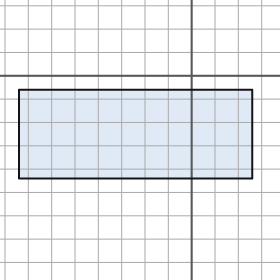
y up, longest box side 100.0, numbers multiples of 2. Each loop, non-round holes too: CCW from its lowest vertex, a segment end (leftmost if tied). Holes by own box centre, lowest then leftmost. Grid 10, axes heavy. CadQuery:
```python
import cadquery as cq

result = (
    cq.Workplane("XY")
    .moveTo(-74.0, -44.0)
    .lineTo(26.0, -44.0)
    .lineTo(26.0, -6.0)
    .lineTo(-74.0, -6.0)
    .close()
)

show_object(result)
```